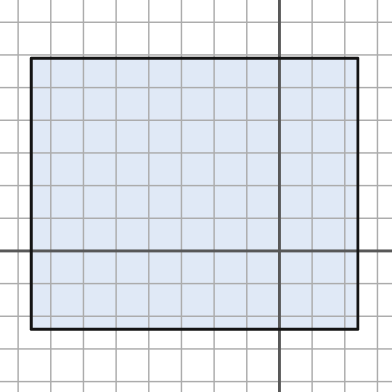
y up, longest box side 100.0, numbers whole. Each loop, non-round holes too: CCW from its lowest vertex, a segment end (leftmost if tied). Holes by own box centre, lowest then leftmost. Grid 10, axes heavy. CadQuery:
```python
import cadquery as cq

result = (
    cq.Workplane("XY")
    .moveTo(-76.0, -24.0)
    .lineTo(24.0, -24.0)
    .lineTo(24.0, 59.0)
    .lineTo(-76.0, 59.0)
    .close()
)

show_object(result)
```